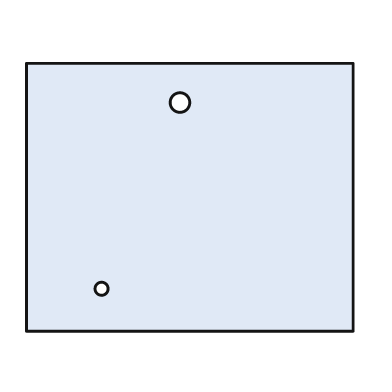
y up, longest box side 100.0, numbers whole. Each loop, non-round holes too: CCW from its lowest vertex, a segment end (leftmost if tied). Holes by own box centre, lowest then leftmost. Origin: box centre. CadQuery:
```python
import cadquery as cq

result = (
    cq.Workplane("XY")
    .moveTo(-50.0, -41.0)
    .lineTo(50.0, -41.0)
    .lineTo(50.0, 41.0)
    .lineTo(-50.0, 41.0)
    .close()
    .moveTo(-27.0, -28.0)
    .circle(2.0)
    .moveTo(-3.0, 29.0)
    .circle(3.0)
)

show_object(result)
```